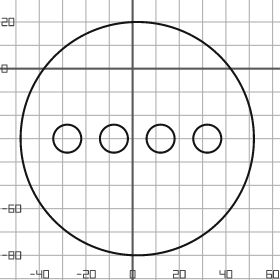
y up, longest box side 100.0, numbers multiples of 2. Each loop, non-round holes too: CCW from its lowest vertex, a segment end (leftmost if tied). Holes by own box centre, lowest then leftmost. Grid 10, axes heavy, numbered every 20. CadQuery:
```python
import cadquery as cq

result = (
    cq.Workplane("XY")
    .moveTo(2.0, -30.0)
    .circle(50.0)
    .moveTo(-28.0, -30.0)
    .circle(6.0)
    .moveTo(-8.0, -30.0)
    .circle(6.0)
    .moveTo(12.0, -30.0)
    .circle(6.0)
    .moveTo(32.0, -30.0)
    .circle(6.0)
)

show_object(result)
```